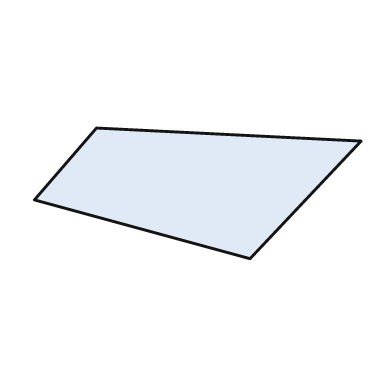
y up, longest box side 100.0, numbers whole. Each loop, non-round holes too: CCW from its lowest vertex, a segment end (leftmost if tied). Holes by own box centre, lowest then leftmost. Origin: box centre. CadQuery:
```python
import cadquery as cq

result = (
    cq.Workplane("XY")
    .moveTo(16.0, -20.0)
    .lineTo(50.0, 16.0)
    .lineTo(-31.0, 20.0)
    .lineTo(-50.0, -2.0)
    .close()
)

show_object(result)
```